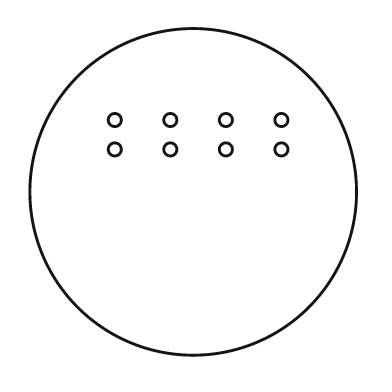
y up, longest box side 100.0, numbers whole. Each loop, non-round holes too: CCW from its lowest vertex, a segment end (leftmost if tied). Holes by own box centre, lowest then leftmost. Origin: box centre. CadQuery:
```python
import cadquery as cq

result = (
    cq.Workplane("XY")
    .moveTo(0.0, 0.0)
    .circle(50.0)
    .moveTo(-24.0, 13.0)
    .circle(2.0)
    .moveTo(-7.0, 13.0)
    .circle(2.0)
    .moveTo(10.0, 13.0)
    .circle(2.0)
    .moveTo(27.0, 13.0)
    .circle(2.0)
    .moveTo(-24.0, 22.0)
    .circle(2.0)
    .moveTo(-7.0, 22.0)
    .circle(2.0)
    .moveTo(10.0, 22.0)
    .circle(2.0)
    .moveTo(27.0, 22.0)
    .circle(2.0)
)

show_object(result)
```